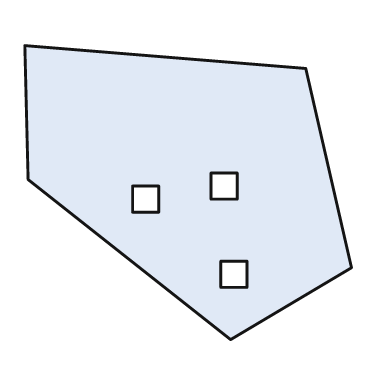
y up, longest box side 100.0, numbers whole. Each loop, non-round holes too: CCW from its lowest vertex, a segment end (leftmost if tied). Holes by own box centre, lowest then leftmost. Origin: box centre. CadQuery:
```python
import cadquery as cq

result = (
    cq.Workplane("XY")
    .moveTo(13.0, -45.0)
    .lineTo(50.0, -23.0)
    .lineTo(36.0, 38.0)
    .lineTo(-50.0, 45.0)
    .lineTo(-49.0, 4.0)
    .close()
    .moveTo(10.0, -29.0)
    .lineTo(18.0, -29.0)
    .lineTo(18.0, -21.0)
    .lineTo(10.0, -21.0)
    .close()
    .moveTo(-17.0, -6.0)
    .lineTo(-9.0, -6.0)
    .lineTo(-9.0, 2.0)
    .lineTo(-17.0, 2.0)
    .close()
    .moveTo(7.0, -2.0)
    .lineTo(15.0, -2.0)
    .lineTo(15.0, 6.0)
    .lineTo(7.0, 6.0)
    .close()
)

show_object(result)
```